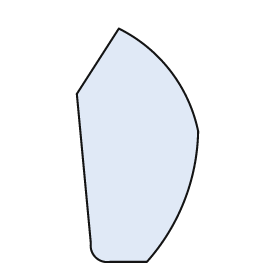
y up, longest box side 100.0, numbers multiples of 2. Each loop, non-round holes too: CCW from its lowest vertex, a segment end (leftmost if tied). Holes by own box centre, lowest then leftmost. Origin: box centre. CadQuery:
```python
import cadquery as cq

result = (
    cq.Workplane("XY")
    .moveTo(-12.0, -50.0)
    .lineTo(4.0, -50.0)
    .threePointArc((20.0, -24.0), (26.0, 6.0))
    .threePointArc((14.0, 32.0), (-8.0, 50.0))
    .lineTo(-26.0, 22.0)
    .lineTo(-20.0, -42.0)
    .threePointArc((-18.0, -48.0), (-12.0, -50.0))
    .close()
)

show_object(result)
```